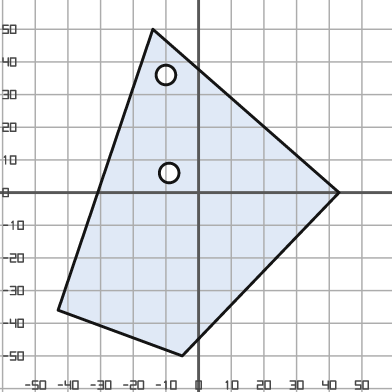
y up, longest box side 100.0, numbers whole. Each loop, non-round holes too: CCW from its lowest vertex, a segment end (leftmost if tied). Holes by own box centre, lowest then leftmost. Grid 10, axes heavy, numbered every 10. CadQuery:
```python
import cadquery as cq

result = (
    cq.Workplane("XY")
    .moveTo(-5.0, -50.0)
    .lineTo(43.0, 0.0)
    .lineTo(-14.0, 50.0)
    .lineTo(-43.0, -36.0)
    .close()
    .moveTo(-9.0, 6.0)
    .circle(3.0)
    .moveTo(-10.0, 36.0)
    .circle(3.0)
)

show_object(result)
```